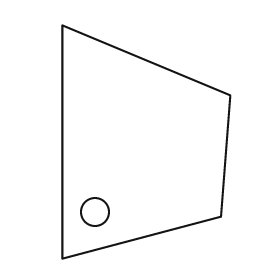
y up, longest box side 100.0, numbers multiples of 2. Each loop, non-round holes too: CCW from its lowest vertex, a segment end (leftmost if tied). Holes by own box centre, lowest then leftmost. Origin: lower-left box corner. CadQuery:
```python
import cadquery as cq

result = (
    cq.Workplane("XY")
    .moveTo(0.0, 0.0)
    .lineTo(68.0, 18.0)
    .lineTo(72.0, 70.0)
    .lineTo(0.0, 100.0)
    .close()
    .moveTo(14.0, 20.0)
    .circle(6.0)
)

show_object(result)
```